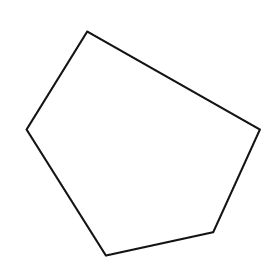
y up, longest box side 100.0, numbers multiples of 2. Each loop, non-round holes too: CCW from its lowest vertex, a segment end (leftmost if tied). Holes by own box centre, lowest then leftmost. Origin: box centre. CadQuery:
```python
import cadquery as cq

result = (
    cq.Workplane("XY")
    .moveTo(-16.0, -48.0)
    .lineTo(30.0, -38.0)
    .lineTo(50.0, 6.0)
    .lineTo(-24.0, 48.0)
    .lineTo(-50.0, 6.0)
    .close()
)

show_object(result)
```